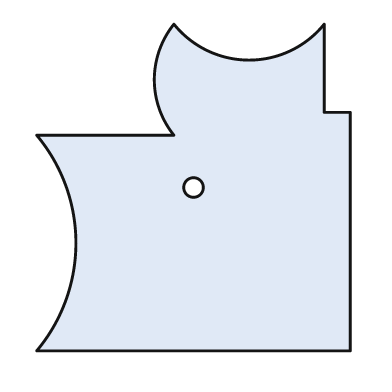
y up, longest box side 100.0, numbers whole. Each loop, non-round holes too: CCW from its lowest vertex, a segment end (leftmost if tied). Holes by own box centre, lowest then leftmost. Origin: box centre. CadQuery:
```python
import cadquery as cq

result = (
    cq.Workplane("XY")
    .moveTo(-48.0, -50.0)
    .lineTo(48.0, -50.0)
    .lineTo(48.0, 23.0)
    .lineTo(40.0, 23.0)
    .lineTo(40.0, 50.0)
    .threePointArc((17.0, 39.0), (-6.0, 50.0))
    .threePointArc((-12.0, 33.0), (-6.0, 16.0))
    .lineTo(-48.0, 16.0)
    .threePointArc((-36.0, -17.0), (-48.0, -50.0))
    .close()
    .moveTo(0.0, 0.0)
    .circle(3.0)
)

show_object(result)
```